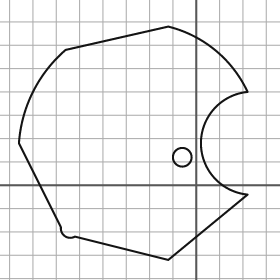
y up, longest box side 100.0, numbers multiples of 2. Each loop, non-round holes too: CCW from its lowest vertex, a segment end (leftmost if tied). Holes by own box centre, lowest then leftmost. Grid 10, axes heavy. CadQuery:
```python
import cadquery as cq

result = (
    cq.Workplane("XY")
    .moveTo(-12.0, -32.0)
    .lineTo(22.0, -4.0)
    .threePointArc((2.0, 18.0), (22.0, 40.0))
    .threePointArc((8.0, 58.0), (-12.0, 68.0))
    .lineTo(-56.0, 58.0)
    .threePointArc((-70.0, 40.0), (-76.0, 18.0))
    .lineTo(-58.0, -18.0)
    .threePointArc((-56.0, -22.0), (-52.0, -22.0))
    .close()
    .moveTo(-6.0, 12.0)
    .circle(4.0)
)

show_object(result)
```